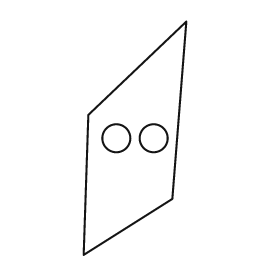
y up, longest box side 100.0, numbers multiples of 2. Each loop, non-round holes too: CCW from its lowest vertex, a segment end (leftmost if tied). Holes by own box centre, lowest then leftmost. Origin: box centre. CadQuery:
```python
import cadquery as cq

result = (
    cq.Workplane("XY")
    .moveTo(-22.0, -50.0)
    .lineTo(16.0, -26.0)
    .lineTo(22.0, 50.0)
    .lineTo(-20.0, 10.0)
    .close()
    .moveTo(-8.0, 0.0)
    .circle(6.0)
    .moveTo(8.0, 0.0)
    .circle(6.0)
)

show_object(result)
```